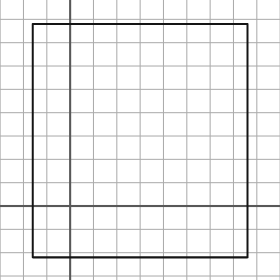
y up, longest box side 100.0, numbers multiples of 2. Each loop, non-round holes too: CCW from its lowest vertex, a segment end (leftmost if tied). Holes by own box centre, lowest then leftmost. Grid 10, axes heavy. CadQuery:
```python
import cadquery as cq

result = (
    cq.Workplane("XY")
    .moveTo(-16.0, -22.0)
    .lineTo(76.0, -22.0)
    .lineTo(76.0, 78.0)
    .lineTo(-16.0, 78.0)
    .close()
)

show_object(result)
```